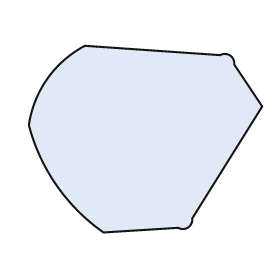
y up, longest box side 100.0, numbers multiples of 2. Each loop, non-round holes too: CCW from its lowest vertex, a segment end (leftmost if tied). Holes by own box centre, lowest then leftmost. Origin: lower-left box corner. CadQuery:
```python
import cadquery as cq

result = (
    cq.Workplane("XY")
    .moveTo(32.0, 0.0)
    .lineTo(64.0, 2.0)
    .threePointArc((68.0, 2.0), (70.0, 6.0))
    .lineTo(100.0, 54.0)
    .lineTo(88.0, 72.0)
    .threePointArc((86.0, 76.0), (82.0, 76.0))
    .lineTo(24.0, 80.0)
    .threePointArc((8.0, 66.0), (0.0, 46.0))
    .threePointArc((12.0, 20.0), (32.0, 0.0))
    .close()
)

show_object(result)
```